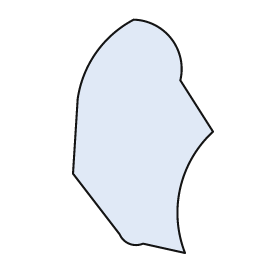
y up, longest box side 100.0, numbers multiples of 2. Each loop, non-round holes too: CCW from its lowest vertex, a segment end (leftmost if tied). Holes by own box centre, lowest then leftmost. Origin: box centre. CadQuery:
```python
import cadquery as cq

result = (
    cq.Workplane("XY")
    .moveTo(18.0, -50.0)
    .threePointArc((16.0, -22.0), (30.0, 2.0))
    .lineTo(16.0, 24.0)
    .threePointArc((12.0, 42.0), (-4.0, 50.0))
    .threePointArc((-20.0, 36.0), (-28.0, 16.0))
    .lineTo(-30.0, -16.0)
    .lineTo(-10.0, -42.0)
    .threePointArc((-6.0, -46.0), (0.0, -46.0))
    .close()
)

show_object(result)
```